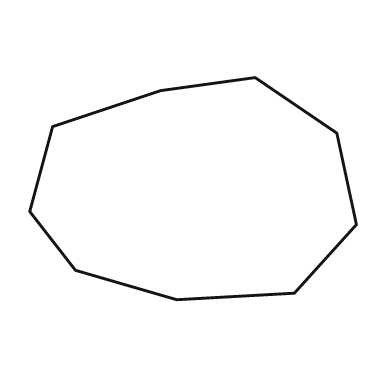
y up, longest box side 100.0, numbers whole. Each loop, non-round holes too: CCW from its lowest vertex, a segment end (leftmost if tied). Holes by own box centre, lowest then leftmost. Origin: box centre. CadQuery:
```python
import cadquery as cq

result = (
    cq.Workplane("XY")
    .moveTo(-5.0, -34.0)
    .lineTo(31.0, -32.0)
    .lineTo(50.0, -11.0)
    .lineTo(44.0, 17.0)
    .lineTo(19.0, 34.0)
    .lineTo(-10.0, 30.0)
    .lineTo(-43.0, 19.0)
    .lineTo(-50.0, -7.0)
    .lineTo(-36.0, -25.0)
    .close()
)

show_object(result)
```